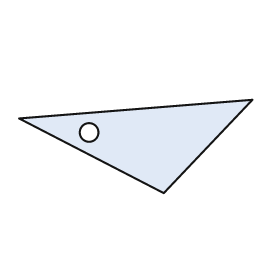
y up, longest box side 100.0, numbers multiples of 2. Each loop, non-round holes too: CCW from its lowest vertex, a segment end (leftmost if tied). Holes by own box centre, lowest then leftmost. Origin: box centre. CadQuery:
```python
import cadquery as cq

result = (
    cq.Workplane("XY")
    .moveTo(12.0, -20.0)
    .lineTo(50.0, 20.0)
    .lineTo(-50.0, 12.0)
    .close()
    .moveTo(-20.0, 6.0)
    .circle(4.0)
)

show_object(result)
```